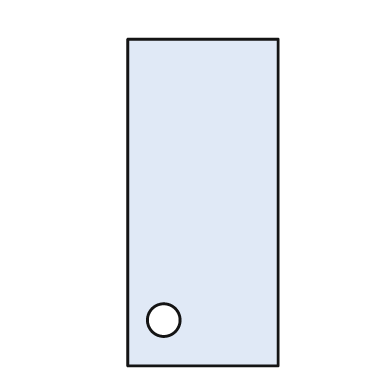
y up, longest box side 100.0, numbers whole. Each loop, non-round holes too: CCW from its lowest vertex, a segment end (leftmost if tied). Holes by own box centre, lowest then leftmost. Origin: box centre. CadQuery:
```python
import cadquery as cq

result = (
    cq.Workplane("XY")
    .moveTo(-23.0, -50.0)
    .lineTo(23.0, -50.0)
    .lineTo(23.0, 50.0)
    .lineTo(-23.0, 50.0)
    .close()
    .moveTo(-12.0, -36.0)
    .circle(5.0)
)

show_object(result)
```